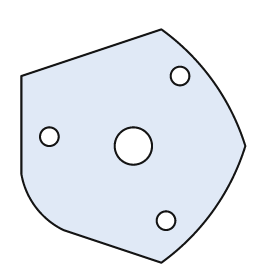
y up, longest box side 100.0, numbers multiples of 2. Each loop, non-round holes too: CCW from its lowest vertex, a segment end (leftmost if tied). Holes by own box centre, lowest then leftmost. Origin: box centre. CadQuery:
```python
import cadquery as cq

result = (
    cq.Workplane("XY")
    .moveTo(12.0, -50.0)
    .threePointArc((34.0, -28.0), (48.0, 0.0))
    .threePointArc((34.0, 28.0), (12.0, 50.0))
    .lineTo(-48.0, 30.0)
    .lineTo(-48.0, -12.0)
    .threePointArc((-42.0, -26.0), (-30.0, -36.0))
    .close()
    .moveTo(14.0, -32.0)
    .circle(4.0)
    .moveTo(0.0, 0.0)
    .circle(8.0)
    .moveTo(-36.0, 4.0)
    .circle(4.0)
    .moveTo(20.0, 30.0)
    .circle(4.0)
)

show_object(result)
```